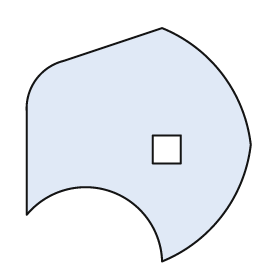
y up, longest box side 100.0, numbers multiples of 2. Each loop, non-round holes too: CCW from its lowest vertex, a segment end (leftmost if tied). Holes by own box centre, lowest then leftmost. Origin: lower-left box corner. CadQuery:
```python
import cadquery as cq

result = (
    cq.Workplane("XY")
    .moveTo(58.0, 0.0)
    .threePointArc((84.0, 20.0), (96.0, 50.0))
    .threePointArc((84.0, 80.0), (58.0, 100.0))
    .lineTo(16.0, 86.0)
    .threePointArc((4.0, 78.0), (0.0, 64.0))
    .lineTo(0.0, 20.0)
    .threePointArc((36.0, 30.0), (58.0, 0.0))
    .close()
    .moveTo(54.0, 42.0)
    .lineTo(66.0, 42.0)
    .lineTo(66.0, 54.0)
    .lineTo(54.0, 54.0)
    .close()
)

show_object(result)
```